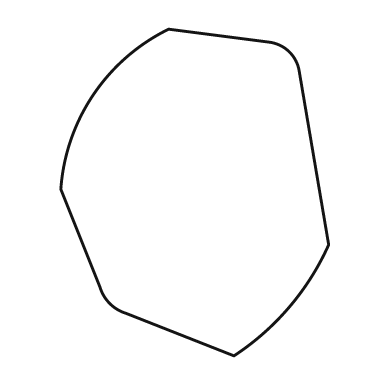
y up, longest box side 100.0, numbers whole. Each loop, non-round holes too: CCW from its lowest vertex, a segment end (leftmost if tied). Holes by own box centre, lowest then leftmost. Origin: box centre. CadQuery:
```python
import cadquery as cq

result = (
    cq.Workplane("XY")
    .moveTo(12.0, -50.0)
    .threePointArc((29.0, -35.0), (41.0, -16.0))
    .lineTo(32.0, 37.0)
    .threePointArc((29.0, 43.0), (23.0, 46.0))
    .lineTo(-8.0, 50.0)
    .threePointArc((-31.0, 30.0), (-41.0, 1.0))
    .lineTo(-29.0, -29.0)
    .threePointArc((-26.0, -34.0), (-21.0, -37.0))
    .close()
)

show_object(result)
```